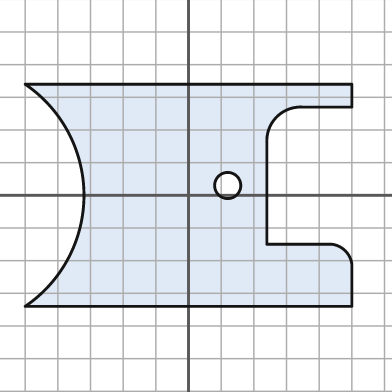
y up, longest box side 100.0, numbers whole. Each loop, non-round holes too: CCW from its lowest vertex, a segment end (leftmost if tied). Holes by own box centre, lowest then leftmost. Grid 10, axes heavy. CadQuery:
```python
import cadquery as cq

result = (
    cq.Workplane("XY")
    .moveTo(-50.0, -34.0)
    .lineTo(50.0, -34.0)
    .lineTo(50.0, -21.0)
    .threePointArc((48.0, -17.0), (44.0, -15.0))
    .lineTo(24.0, -15.0)
    .lineTo(24.0, 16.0)
    .threePointArc((27.0, 24.0), (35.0, 27.0))
    .lineTo(50.0, 27.0)
    .lineTo(50.0, 34.0)
    .lineTo(-50.0, 34.0)
    .threePointArc((-32.0, 0.0), (-50.0, -34.0))
    .close()
    .moveTo(12.0, 3.0)
    .circle(4.0)
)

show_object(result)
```